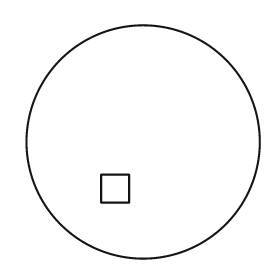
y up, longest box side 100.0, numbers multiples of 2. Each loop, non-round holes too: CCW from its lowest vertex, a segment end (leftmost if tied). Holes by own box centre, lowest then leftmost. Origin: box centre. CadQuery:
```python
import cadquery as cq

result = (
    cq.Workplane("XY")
    .moveTo(0.0, 0.0)
    .circle(50.0)
    .moveTo(-18.0, -26.0)
    .lineTo(-6.0, -26.0)
    .lineTo(-6.0, -14.0)
    .lineTo(-18.0, -14.0)
    .close()
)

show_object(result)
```